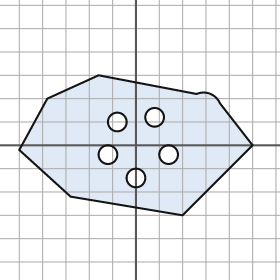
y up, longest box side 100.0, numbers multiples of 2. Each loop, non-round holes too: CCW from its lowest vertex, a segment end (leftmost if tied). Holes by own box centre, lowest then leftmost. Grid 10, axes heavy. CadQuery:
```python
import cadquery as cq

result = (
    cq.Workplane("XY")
    .moveTo(20.0, -30.0)
    .lineTo(50.0, 0.0)
    .lineTo(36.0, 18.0)
    .threePointArc((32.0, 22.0), (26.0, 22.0))
    .lineTo(-16.0, 30.0)
    .lineTo(-38.0, 20.0)
    .lineTo(-50.0, -2.0)
    .lineTo(-28.0, -22.0)
    .close()
    .moveTo(0.0, -14.0)
    .circle(4.0)
    .moveTo(-12.0, -4.0)
    .circle(4.0)
    .moveTo(14.0, -4.0)
    .circle(4.0)
    .moveTo(-8.0, 10.0)
    .circle(4.0)
    .moveTo(8.0, 12.0)
    .circle(4.0)
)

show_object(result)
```